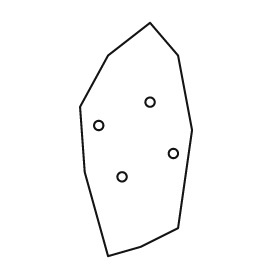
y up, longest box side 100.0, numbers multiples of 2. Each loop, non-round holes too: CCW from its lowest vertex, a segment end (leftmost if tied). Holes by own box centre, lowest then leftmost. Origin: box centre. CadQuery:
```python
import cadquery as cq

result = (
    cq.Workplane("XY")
    .moveTo(-12.0, -50.0)
    .lineTo(2.0, -46.0)
    .lineTo(18.0, -38.0)
    .lineTo(24.0, 4.0)
    .lineTo(18.0, 36.0)
    .lineTo(6.0, 50.0)
    .lineTo(-12.0, 36.0)
    .lineTo(-24.0, 14.0)
    .lineTo(-22.0, -14.0)
    .close()
    .moveTo(-6.0, -16.0)
    .circle(2.0)
    .moveTo(16.0, -6.0)
    .circle(2.0)
    .moveTo(-16.0, 6.0)
    .circle(2.0)
    .moveTo(6.0, 16.0)
    .circle(2.0)
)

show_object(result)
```